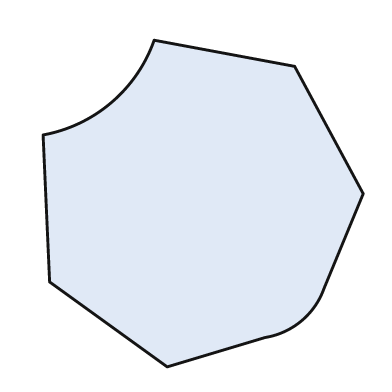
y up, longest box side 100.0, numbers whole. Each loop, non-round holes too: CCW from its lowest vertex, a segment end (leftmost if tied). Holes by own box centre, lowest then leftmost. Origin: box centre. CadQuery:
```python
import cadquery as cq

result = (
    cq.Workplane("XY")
    .moveTo(-11.0, -50.0)
    .lineTo(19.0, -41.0)
    .threePointArc((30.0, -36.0), (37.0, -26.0))
    .lineTo(49.0, 3.0)
    .lineTo(28.0, 42.0)
    .lineTo(-15.0, 50.0)
    .threePointArc((-28.0, 31.0), (-49.0, 21.0))
    .lineTo(-47.0, -24.0)
    .close()
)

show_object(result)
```